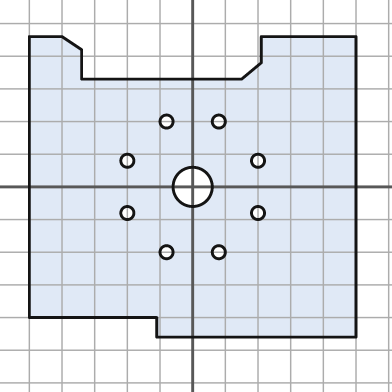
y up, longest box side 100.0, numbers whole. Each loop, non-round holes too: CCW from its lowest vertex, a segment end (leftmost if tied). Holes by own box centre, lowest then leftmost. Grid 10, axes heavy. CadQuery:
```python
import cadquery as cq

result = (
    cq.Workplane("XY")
    .moveTo(-11.0, -46.0)
    .lineTo(50.0, -46.0)
    .lineTo(50.0, 46.0)
    .lineTo(21.0, 46.0)
    .lineTo(21.0, 38.0)
    .lineTo(15.0, 33.0)
    .lineTo(-34.0, 33.0)
    .lineTo(-34.0, 42.0)
    .lineTo(-40.0, 46.0)
    .lineTo(-50.0, 46.0)
    .lineTo(-50.0, -40.0)
    .lineTo(-11.0, -40.0)
    .close()
    .moveTo(-8.0, -20.0)
    .circle(2.0)
    .moveTo(8.0, -20.0)
    .circle(2.0)
    .moveTo(-20.0, -8.0)
    .circle(2.0)
    .moveTo(20.0, -8.0)
    .circle(2.0)
    .moveTo(0.0, 0.0)
    .circle(6.0)
    .moveTo(-20.0, 8.0)
    .circle(2.0)
    .moveTo(20.0, 8.0)
    .circle(2.0)
    .moveTo(-8.0, 20.0)
    .circle(2.0)
    .moveTo(8.0, 20.0)
    .circle(2.0)
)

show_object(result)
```